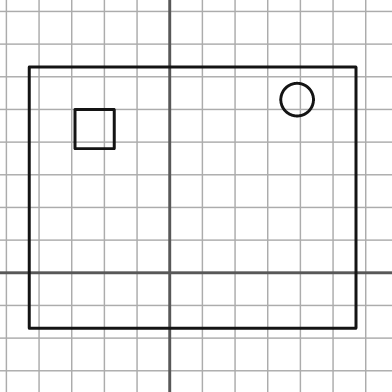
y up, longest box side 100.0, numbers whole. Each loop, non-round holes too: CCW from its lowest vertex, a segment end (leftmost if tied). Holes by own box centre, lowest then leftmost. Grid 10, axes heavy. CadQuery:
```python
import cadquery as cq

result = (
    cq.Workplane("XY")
    .moveTo(-43.0, -17.0)
    .lineTo(57.0, -17.0)
    .lineTo(57.0, 63.0)
    .lineTo(-43.0, 63.0)
    .close()
    .moveTo(-29.0, 38.0)
    .lineTo(-17.0, 38.0)
    .lineTo(-17.0, 50.0)
    .lineTo(-29.0, 50.0)
    .close()
    .moveTo(39.0, 53.0)
    .circle(5.0)
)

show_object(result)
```